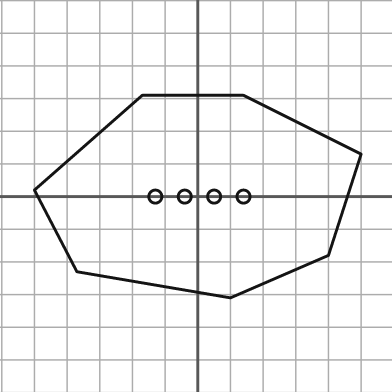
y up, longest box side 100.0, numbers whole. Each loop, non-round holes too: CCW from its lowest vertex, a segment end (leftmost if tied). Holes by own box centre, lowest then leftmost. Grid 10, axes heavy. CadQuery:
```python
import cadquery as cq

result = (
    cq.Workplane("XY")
    .moveTo(10.0, -31.0)
    .lineTo(40.0, -18.0)
    .lineTo(50.0, 13.0)
    .lineTo(14.0, 31.0)
    .lineTo(-17.0, 31.0)
    .lineTo(-50.0, 2.0)
    .lineTo(-37.0, -23.0)
    .close()
    .moveTo(-13.0, 0.0)
    .circle(2.0)
    .moveTo(-4.0, 0.0)
    .circle(2.0)
    .moveTo(5.0, 0.0)
    .circle(2.0)
    .moveTo(14.0, 0.0)
    .circle(2.0)
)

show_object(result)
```